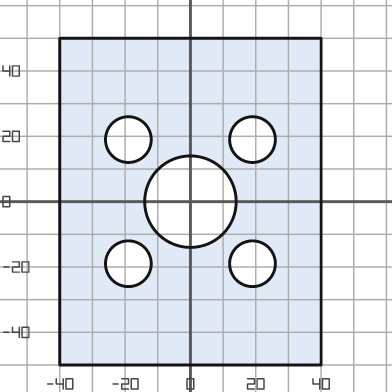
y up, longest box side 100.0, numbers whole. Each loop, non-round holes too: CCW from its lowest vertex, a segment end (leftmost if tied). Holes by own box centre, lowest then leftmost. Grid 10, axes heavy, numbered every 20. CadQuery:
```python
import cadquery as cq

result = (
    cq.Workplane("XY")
    .moveTo(-40.0, -50.0)
    .lineTo(40.0, -50.0)
    .lineTo(40.0, 50.0)
    .lineTo(-40.0, 50.0)
    .close()
    .moveTo(-19.0, -19.0)
    .circle(7.0)
    .moveTo(19.0, -19.0)
    .circle(7.0)
    .moveTo(0.0, 0.0)
    .circle(14.0)
    .moveTo(-19.0, 19.0)
    .circle(7.0)
    .moveTo(19.0, 19.0)
    .circle(7.0)
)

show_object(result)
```